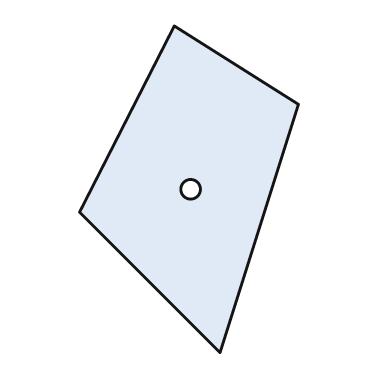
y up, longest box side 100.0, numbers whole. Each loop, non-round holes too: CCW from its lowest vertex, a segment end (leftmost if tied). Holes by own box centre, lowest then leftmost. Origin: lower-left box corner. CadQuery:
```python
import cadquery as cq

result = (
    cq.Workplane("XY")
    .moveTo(43.0, 0.0)
    .lineTo(67.0, 76.0)
    .lineTo(29.0, 100.0)
    .lineTo(0.0, 43.0)
    .close()
    .moveTo(34.0, 50.0)
    .circle(3.0)
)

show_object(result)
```